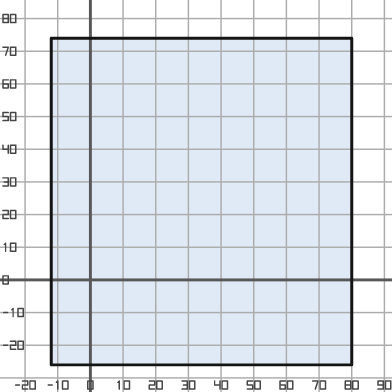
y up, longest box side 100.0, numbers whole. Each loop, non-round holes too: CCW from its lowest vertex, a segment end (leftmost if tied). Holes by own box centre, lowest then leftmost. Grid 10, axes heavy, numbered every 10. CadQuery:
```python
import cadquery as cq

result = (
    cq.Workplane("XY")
    .moveTo(-12.0, -26.0)
    .lineTo(80.0, -26.0)
    .lineTo(80.0, 74.0)
    .lineTo(-12.0, 74.0)
    .close()
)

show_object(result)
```